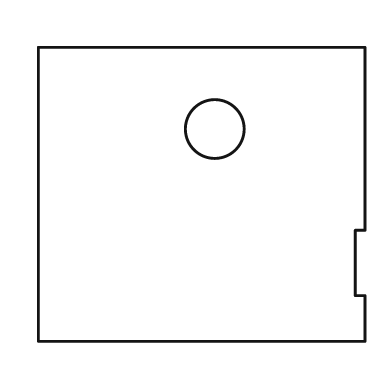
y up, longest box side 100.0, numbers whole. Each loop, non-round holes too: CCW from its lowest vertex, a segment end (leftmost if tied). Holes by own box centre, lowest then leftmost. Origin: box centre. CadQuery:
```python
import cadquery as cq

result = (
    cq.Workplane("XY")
    .moveTo(-50.0, -45.0)
    .lineTo(50.0, -45.0)
    .lineTo(50.0, -31.0)
    .lineTo(47.0, -31.0)
    .lineTo(47.0, -11.0)
    .lineTo(50.0, -11.0)
    .lineTo(50.0, 45.0)
    .lineTo(-50.0, 45.0)
    .close()
    .moveTo(4.0, 20.0)
    .circle(9.0)
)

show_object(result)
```